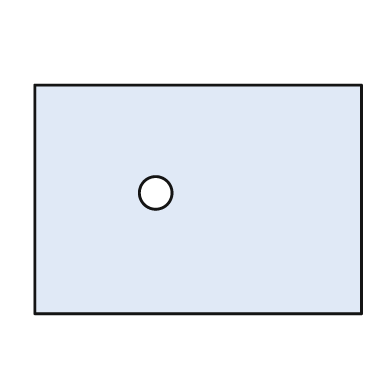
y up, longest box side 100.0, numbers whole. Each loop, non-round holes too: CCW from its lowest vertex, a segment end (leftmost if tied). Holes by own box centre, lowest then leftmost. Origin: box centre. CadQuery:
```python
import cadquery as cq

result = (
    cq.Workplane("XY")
    .moveTo(-50.0, -35.0)
    .lineTo(50.0, -35.0)
    .lineTo(50.0, 35.0)
    .lineTo(-50.0, 35.0)
    .close()
    .moveTo(-13.0, 2.0)
    .circle(5.0)
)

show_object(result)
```